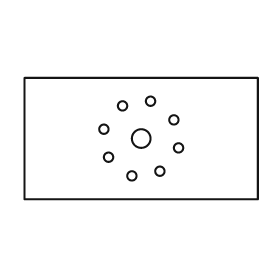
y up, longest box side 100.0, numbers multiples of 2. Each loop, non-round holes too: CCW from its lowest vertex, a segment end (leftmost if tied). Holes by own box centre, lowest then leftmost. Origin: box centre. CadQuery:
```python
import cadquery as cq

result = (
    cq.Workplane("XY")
    .moveTo(-50.0, -26.0)
    .lineTo(50.0, -26.0)
    .lineTo(50.0, 26.0)
    .lineTo(-50.0, 26.0)
    .close()
    .moveTo(-4.0, -16.0)
    .circle(2.0)
    .moveTo(8.0, -14.0)
    .circle(2.0)
    .moveTo(-14.0, -8.0)
    .circle(2.0)
    .moveTo(16.0, -4.0)
    .circle(2.0)
    .moveTo(0.0, 0.0)
    .circle(4.0)
    .moveTo(-16.0, 4.0)
    .circle(2.0)
    .moveTo(14.0, 8.0)
    .circle(2.0)
    .moveTo(-8.0, 14.0)
    .circle(2.0)
    .moveTo(4.0, 16.0)
    .circle(2.0)
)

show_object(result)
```